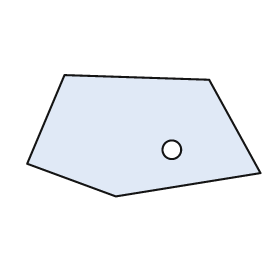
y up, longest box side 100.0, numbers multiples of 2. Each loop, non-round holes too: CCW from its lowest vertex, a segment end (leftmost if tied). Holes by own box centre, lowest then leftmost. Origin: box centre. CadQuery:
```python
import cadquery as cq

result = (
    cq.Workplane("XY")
    .moveTo(-12.0, -26.0)
    .lineTo(50.0, -16.0)
    .lineTo(28.0, 24.0)
    .lineTo(-34.0, 26.0)
    .lineTo(-50.0, -12.0)
    .close()
    .moveTo(12.0, -6.0)
    .circle(4.0)
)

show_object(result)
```